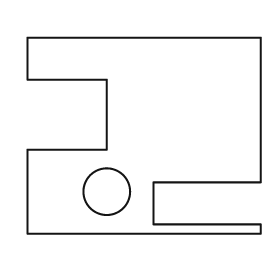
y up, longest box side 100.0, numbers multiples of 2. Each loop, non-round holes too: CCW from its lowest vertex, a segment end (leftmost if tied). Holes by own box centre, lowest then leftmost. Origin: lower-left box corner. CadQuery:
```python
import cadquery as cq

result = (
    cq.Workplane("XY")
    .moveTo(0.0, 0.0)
    .lineTo(100.0, 0.0)
    .lineTo(100.0, 4.0)
    .lineTo(54.0, 4.0)
    .lineTo(54.0, 22.0)
    .lineTo(100.0, 22.0)
    .lineTo(100.0, 84.0)
    .lineTo(0.0, 84.0)
    .lineTo(0.0, 66.0)
    .lineTo(34.0, 66.0)
    .lineTo(34.0, 36.0)
    .lineTo(0.0, 36.0)
    .close()
    .moveTo(34.0, 18.0)
    .circle(10.0)
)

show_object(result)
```